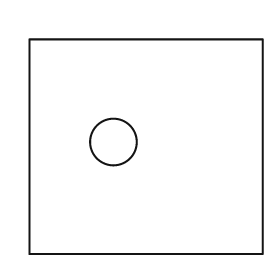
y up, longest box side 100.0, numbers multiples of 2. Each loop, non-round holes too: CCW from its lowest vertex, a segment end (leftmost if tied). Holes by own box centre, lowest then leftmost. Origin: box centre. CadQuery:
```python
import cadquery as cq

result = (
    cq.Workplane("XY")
    .moveTo(-50.0, -46.0)
    .lineTo(50.0, -46.0)
    .lineTo(50.0, 46.0)
    .lineTo(-50.0, 46.0)
    .close()
    .moveTo(-14.0, 2.0)
    .circle(10.0)
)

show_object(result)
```